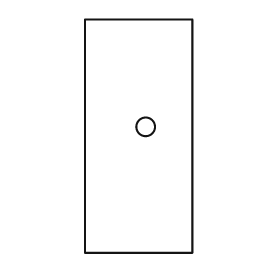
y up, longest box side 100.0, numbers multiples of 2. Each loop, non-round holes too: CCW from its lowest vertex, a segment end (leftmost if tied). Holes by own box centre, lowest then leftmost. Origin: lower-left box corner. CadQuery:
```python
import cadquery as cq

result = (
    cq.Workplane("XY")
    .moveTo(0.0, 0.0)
    .lineTo(46.0, 0.0)
    .lineTo(46.0, 100.0)
    .lineTo(0.0, 100.0)
    .close()
    .moveTo(26.0, 54.0)
    .circle(4.0)
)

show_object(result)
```